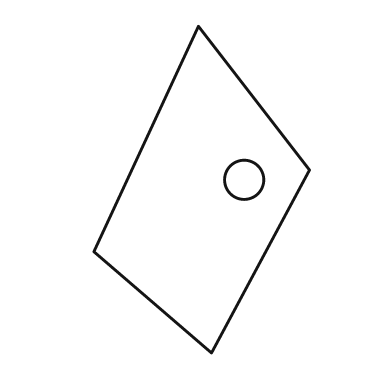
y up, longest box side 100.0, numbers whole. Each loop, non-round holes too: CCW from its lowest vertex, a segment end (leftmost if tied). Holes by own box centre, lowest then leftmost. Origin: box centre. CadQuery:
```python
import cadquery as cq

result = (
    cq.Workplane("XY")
    .moveTo(3.0, -50.0)
    .lineTo(33.0, 6.0)
    .lineTo(-1.0, 50.0)
    .lineTo(-33.0, -19.0)
    .close()
    .moveTo(13.0, 3.0)
    .circle(6.0)
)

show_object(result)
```